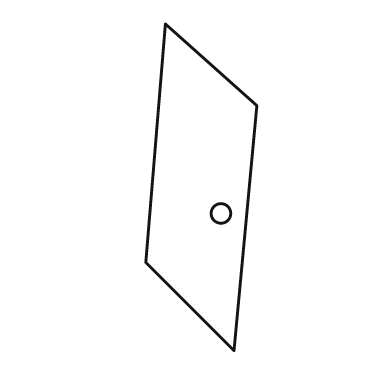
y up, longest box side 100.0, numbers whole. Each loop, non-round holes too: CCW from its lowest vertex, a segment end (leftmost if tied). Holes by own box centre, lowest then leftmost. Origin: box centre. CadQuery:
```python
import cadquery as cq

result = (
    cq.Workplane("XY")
    .moveTo(10.0, -50.0)
    .lineTo(17.0, 25.0)
    .lineTo(-11.0, 50.0)
    .lineTo(-17.0, -23.0)
    .close()
    .moveTo(6.0, -8.0)
    .circle(3.0)
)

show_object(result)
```